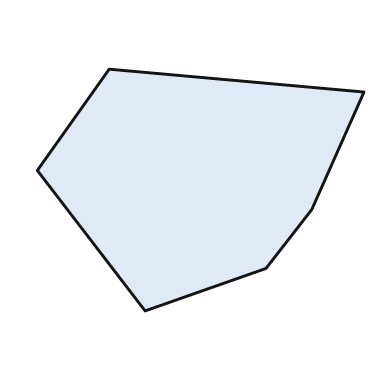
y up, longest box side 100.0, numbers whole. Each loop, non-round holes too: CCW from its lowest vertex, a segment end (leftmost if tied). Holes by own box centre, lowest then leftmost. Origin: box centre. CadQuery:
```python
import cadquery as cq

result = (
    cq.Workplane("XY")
    .moveTo(-17.0, -37.0)
    .lineTo(20.0, -24.0)
    .lineTo(34.0, -6.0)
    .lineTo(50.0, 30.0)
    .lineTo(-28.0, 37.0)
    .lineTo(-50.0, 6.0)
    .close()
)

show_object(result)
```